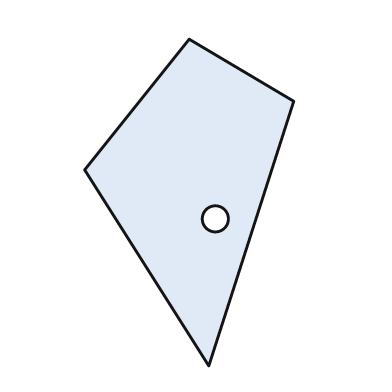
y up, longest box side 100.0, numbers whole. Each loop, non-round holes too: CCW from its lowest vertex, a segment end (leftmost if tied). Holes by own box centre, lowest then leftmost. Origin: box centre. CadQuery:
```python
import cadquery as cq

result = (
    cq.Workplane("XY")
    .moveTo(6.0, -50.0)
    .lineTo(32.0, 31.0)
    .lineTo(0.0, 50.0)
    .lineTo(-32.0, 10.0)
    .close()
    .moveTo(8.0, -5.0)
    .circle(4.0)
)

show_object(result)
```